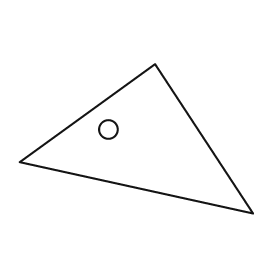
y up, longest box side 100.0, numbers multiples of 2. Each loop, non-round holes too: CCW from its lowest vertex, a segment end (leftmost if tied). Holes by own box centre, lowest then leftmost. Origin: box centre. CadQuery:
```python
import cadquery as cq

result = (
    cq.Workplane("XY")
    .moveTo(50.0, -32.0)
    .lineTo(8.0, 32.0)
    .lineTo(-50.0, -10.0)
    .close()
    .moveTo(-12.0, 4.0)
    .circle(4.0)
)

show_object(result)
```